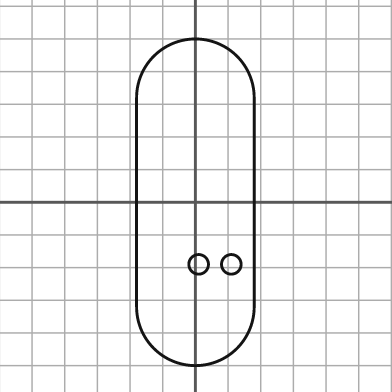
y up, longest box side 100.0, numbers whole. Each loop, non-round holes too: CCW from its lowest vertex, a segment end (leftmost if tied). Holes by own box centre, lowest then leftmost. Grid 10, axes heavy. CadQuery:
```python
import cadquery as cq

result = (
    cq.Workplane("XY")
    .moveTo(-18.0, -32.0)
    .threePointArc((0.0, -50.0), (18.0, -32.0))
    .lineTo(18.0, 32.0)
    .threePointArc((0.0, 50.0), (-18.0, 32.0))
    .close()
    .moveTo(1.0, -19.0)
    .circle(3.0)
    .moveTo(11.0, -19.0)
    .circle(3.0)
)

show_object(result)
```